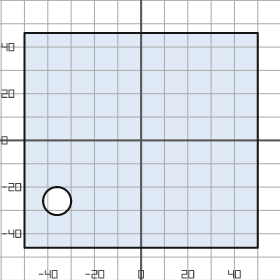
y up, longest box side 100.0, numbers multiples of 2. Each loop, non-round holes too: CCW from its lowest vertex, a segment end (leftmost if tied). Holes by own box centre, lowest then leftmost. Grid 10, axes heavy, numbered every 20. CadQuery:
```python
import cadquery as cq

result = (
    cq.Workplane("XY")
    .moveTo(-50.0, -46.0)
    .lineTo(50.0, -46.0)
    .lineTo(50.0, 46.0)
    .lineTo(-50.0, 46.0)
    .close()
    .moveTo(-36.0, -26.0)
    .circle(6.0)
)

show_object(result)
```